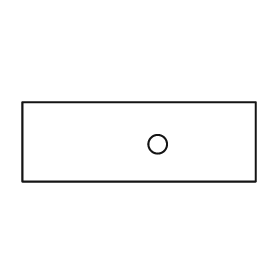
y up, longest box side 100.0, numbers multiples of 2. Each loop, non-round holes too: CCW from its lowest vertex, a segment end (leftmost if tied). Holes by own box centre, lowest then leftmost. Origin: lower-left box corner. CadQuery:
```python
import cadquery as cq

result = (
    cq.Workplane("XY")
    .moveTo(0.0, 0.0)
    .lineTo(100.0, 0.0)
    .lineTo(100.0, 34.0)
    .lineTo(0.0, 34.0)
    .close()
    .moveTo(58.0, 16.0)
    .circle(4.0)
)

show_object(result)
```